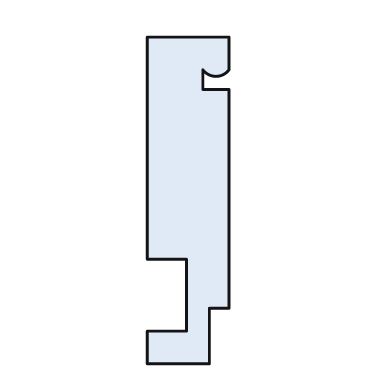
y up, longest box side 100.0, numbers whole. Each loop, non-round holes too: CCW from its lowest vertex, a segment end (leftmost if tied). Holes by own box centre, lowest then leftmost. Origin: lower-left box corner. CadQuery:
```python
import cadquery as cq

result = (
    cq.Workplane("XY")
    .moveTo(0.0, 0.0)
    .lineTo(19.0, 0.0)
    .lineTo(19.0, 17.0)
    .lineTo(25.0, 17.0)
    .lineTo(25.0, 84.0)
    .lineTo(17.0, 84.0)
    .lineTo(17.0, 90.0)
    .threePointArc((21.0, 88.0), (25.0, 90.0))
    .lineTo(25.0, 100.0)
    .lineTo(0.0, 100.0)
    .lineTo(0.0, 32.0)
    .lineTo(12.0, 32.0)
    .lineTo(12.0, 10.0)
    .lineTo(0.0, 10.0)
    .close()
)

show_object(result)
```